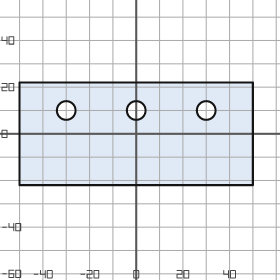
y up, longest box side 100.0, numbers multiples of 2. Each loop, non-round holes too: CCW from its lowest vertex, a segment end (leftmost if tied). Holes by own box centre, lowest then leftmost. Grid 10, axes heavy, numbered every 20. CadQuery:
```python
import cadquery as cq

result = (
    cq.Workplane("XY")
    .moveTo(-50.0, -22.0)
    .lineTo(50.0, -22.0)
    .lineTo(50.0, 22.0)
    .lineTo(-50.0, 22.0)
    .close()
    .moveTo(-30.0, 10.0)
    .circle(4.0)
    .moveTo(0.0, 10.0)
    .circle(4.0)
    .moveTo(30.0, 10.0)
    .circle(4.0)
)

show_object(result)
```